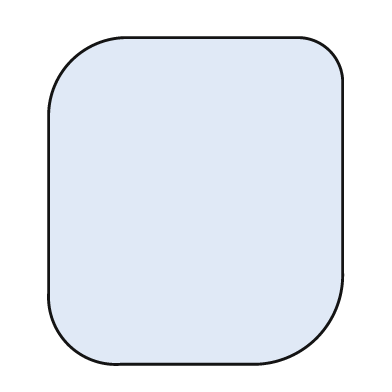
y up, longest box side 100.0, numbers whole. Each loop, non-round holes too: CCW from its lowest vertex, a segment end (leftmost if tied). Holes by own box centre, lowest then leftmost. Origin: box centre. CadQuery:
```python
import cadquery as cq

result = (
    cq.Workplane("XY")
    .moveTo(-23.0, -50.0)
    .lineTo(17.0, -50.0)
    .threePointArc((37.0, -42.0), (45.0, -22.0))
    .lineTo(45.0, 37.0)
    .threePointArc((41.0, 46.0), (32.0, 50.0))
    .lineTo(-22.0, 50.0)
    .threePointArc((-38.0, 43.0), (-45.0, 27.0))
    .lineTo(-45.0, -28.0)
    .threePointArc((-39.0, -44.0), (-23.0, -50.0))
    .close()
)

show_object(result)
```